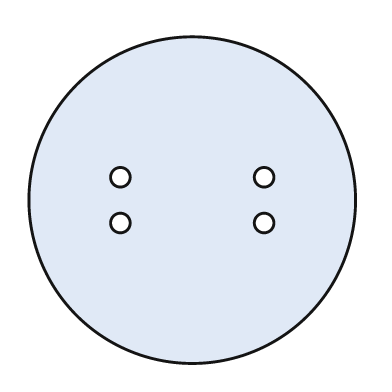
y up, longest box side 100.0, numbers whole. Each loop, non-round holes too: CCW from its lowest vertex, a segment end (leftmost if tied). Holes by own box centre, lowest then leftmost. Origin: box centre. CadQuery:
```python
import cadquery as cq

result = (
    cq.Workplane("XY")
    .moveTo(0.0, 0.0)
    .circle(50.0)
    .moveTo(-22.0, -7.0)
    .circle(3.0)
    .moveTo(22.0, -7.0)
    .circle(3.0)
    .moveTo(-22.0, 7.0)
    .circle(3.0)
    .moveTo(22.0, 7.0)
    .circle(3.0)
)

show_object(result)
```